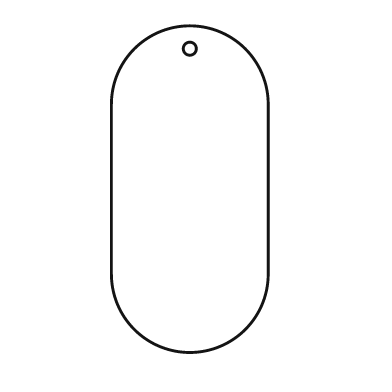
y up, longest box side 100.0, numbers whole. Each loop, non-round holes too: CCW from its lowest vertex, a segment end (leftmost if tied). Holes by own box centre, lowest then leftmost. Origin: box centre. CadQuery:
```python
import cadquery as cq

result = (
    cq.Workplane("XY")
    .moveTo(-24.0, -26.0)
    .threePointArc((0.0, -50.0), (24.0, -26.0))
    .lineTo(24.0, 26.0)
    .threePointArc((0.0, 50.0), (-24.0, 26.0))
    .close()
    .moveTo(0.0, 43.0)
    .circle(2.0)
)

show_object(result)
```